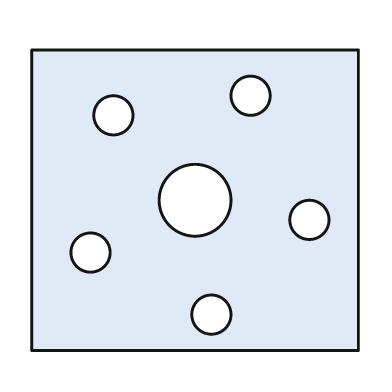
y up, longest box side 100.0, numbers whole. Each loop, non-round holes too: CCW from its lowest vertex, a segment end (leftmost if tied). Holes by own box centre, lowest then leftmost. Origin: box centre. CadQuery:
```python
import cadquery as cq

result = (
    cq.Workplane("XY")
    .moveTo(-50.0, -46.0)
    .lineTo(50.0, -46.0)
    .lineTo(50.0, 46.0)
    .lineTo(-50.0, 46.0)
    .close()
    .moveTo(5.0, -35.0)
    .circle(6.0)
    .moveTo(-32.0, -16.0)
    .circle(6.0)
    .moveTo(35.0, -6.0)
    .circle(6.0)
    .moveTo(0.0, 0.0)
    .circle(11.0)
    .moveTo(-25.0, 26.0)
    .circle(6.0)
    .moveTo(17.0, 32.0)
    .circle(6.0)
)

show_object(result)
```